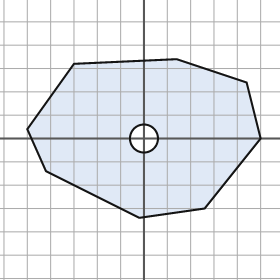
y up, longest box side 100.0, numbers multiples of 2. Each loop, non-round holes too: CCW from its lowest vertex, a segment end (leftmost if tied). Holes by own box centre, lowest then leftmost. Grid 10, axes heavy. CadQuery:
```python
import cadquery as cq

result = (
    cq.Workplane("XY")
    .moveTo(-2.0, -34.0)
    .lineTo(26.0, -30.0)
    .lineTo(50.0, 0.0)
    .lineTo(44.0, 24.0)
    .lineTo(14.0, 34.0)
    .lineTo(-30.0, 32.0)
    .lineTo(-50.0, 4.0)
    .lineTo(-42.0, -14.0)
    .close()
    .moveTo(0.0, 0.0)
    .circle(6.0)
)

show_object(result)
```